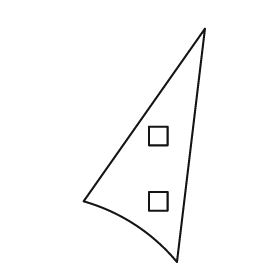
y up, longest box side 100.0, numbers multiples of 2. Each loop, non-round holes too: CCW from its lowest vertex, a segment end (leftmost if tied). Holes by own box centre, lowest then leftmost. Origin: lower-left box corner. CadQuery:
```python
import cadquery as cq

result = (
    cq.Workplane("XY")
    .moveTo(40.0, 0.0)
    .lineTo(52.0, 100.0)
    .lineTo(0.0, 26.0)
    .threePointArc((22.0, 16.0), (40.0, 0.0))
    .close()
    .moveTo(28.0, 22.0)
    .lineTo(36.0, 22.0)
    .lineTo(36.0, 30.0)
    .lineTo(28.0, 30.0)
    .close()
    .moveTo(28.0, 50.0)
    .lineTo(36.0, 50.0)
    .lineTo(36.0, 58.0)
    .lineTo(28.0, 58.0)
    .close()
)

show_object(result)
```